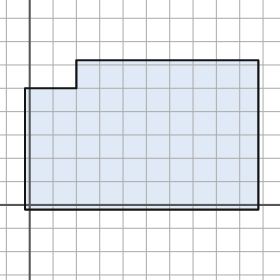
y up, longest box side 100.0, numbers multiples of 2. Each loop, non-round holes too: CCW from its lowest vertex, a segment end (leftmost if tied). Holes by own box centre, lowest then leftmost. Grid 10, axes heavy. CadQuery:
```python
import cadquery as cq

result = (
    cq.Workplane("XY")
    .moveTo(-2.0, -2.0)
    .lineTo(98.0, -2.0)
    .lineTo(98.0, 62.0)
    .lineTo(20.0, 62.0)
    .lineTo(20.0, 50.0)
    .lineTo(-2.0, 50.0)
    .close()
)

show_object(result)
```